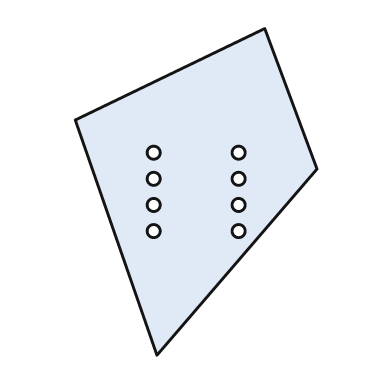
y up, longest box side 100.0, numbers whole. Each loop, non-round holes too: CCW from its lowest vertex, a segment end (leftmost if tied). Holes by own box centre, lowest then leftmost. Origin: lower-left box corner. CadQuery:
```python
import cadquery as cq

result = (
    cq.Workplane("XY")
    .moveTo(25.0, 0.0)
    .lineTo(74.0, 57.0)
    .lineTo(58.0, 100.0)
    .lineTo(0.0, 72.0)
    .close()
    .moveTo(24.0, 38.0)
    .circle(2.0)
    .moveTo(50.0, 38.0)
    .circle(2.0)
    .moveTo(24.0, 46.0)
    .circle(2.0)
    .moveTo(50.0, 46.0)
    .circle(2.0)
    .moveTo(24.0, 54.0)
    .circle(2.0)
    .moveTo(50.0, 54.0)
    .circle(2.0)
    .moveTo(24.0, 62.0)
    .circle(2.0)
    .moveTo(50.0, 62.0)
    .circle(2.0)
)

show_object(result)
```